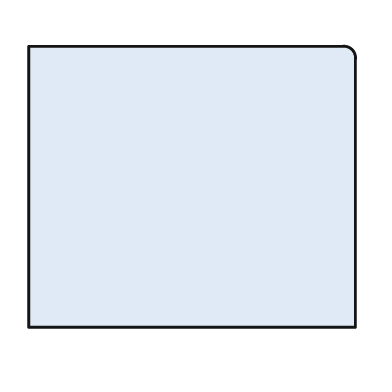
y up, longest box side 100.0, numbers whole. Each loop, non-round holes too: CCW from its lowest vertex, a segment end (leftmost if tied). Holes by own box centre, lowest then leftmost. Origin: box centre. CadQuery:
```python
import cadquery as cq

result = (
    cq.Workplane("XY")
    .moveTo(-50.0, -43.0)
    .lineTo(50.0, -43.0)
    .lineTo(50.0, 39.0)
    .threePointArc((49.0, 42.0), (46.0, 43.0))
    .lineTo(-50.0, 43.0)
    .close()
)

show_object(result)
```